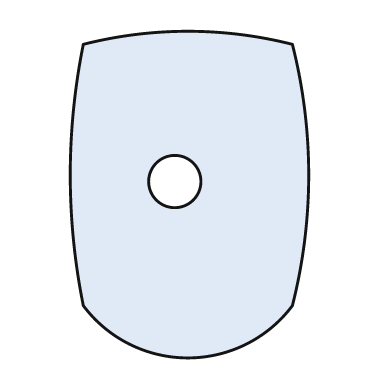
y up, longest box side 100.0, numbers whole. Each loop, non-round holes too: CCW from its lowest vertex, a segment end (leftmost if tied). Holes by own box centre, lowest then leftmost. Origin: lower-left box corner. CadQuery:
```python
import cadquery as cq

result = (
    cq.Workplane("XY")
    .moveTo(4.0, 16.0)
    .threePointArc((36.0, 0.0), (68.0, 16.0))
    .threePointArc((73.0, 56.0), (68.0, 96.0))
    .threePointArc((36.0, 100.0), (4.0, 96.0))
    .threePointArc((0.0, 56.0), (4.0, 16.0))
    .close()
    .moveTo(32.0, 54.0)
    .circle(8.0)
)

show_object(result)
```